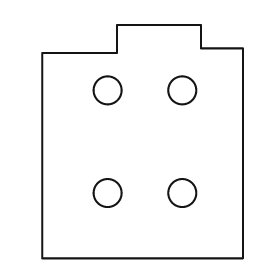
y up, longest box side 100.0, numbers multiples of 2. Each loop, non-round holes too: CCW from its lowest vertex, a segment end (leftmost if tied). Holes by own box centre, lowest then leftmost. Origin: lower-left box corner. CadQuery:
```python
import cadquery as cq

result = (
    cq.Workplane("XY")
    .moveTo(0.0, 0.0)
    .lineTo(86.0, 0.0)
    .lineTo(86.0, 90.0)
    .lineTo(68.0, 90.0)
    .lineTo(68.0, 100.0)
    .lineTo(32.0, 100.0)
    .lineTo(32.0, 88.0)
    .lineTo(0.0, 88.0)
    .close()
    .moveTo(28.0, 28.0)
    .circle(6.0)
    .moveTo(60.0, 28.0)
    .circle(6.0)
    .moveTo(28.0, 72.0)
    .circle(6.0)
    .moveTo(60.0, 72.0)
    .circle(6.0)
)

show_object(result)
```